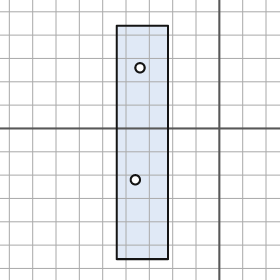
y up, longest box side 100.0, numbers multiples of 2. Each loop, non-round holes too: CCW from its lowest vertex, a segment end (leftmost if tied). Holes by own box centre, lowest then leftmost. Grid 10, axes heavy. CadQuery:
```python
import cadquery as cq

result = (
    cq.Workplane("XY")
    .moveTo(-44.0, -56.0)
    .lineTo(-22.0, -56.0)
    .lineTo(-22.0, 44.0)
    .lineTo(-44.0, 44.0)
    .close()
    .moveTo(-36.0, -22.0)
    .circle(2.0)
    .moveTo(-34.0, 26.0)
    .circle(2.0)
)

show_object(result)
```